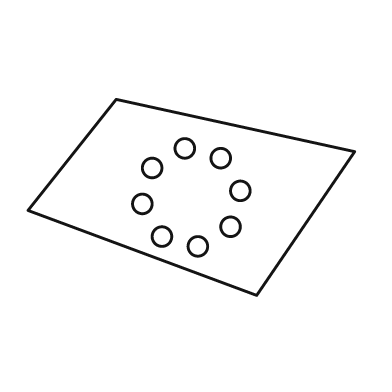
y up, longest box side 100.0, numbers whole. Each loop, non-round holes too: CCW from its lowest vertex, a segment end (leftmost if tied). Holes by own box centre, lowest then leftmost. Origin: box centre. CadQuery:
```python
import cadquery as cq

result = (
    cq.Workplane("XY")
    .moveTo(20.0, -30.0)
    .lineTo(50.0, 14.0)
    .lineTo(-23.0, 30.0)
    .lineTo(-50.0, -4.0)
    .close()
    .moveTo(2.0, -15.0)
    .circle(3.0)
    .moveTo(-9.0, -12.0)
    .circle(3.0)
    .moveTo(12.0, -9.0)
    .circle(3.0)
    .moveTo(-15.0, -2.0)
    .circle(3.0)
    .moveTo(15.0, 2.0)
    .circle(3.0)
    .moveTo(-12.0, 9.0)
    .circle(3.0)
    .moveTo(9.0, 12.0)
    .circle(3.0)
    .moveTo(-2.0, 15.0)
    .circle(3.0)
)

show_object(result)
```